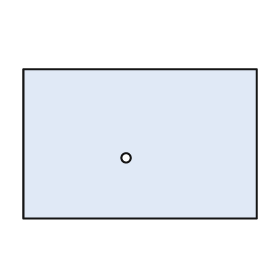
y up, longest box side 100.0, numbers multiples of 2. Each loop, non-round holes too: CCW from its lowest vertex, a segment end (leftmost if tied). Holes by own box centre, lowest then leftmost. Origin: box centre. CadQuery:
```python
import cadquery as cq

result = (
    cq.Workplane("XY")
    .moveTo(-50.0, -32.0)
    .lineTo(50.0, -32.0)
    .lineTo(50.0, 32.0)
    .lineTo(-50.0, 32.0)
    .close()
    .moveTo(-6.0, -6.0)
    .circle(2.0)
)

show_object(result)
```